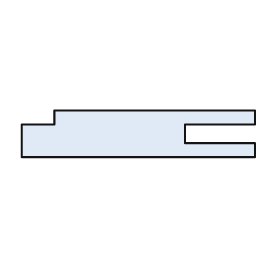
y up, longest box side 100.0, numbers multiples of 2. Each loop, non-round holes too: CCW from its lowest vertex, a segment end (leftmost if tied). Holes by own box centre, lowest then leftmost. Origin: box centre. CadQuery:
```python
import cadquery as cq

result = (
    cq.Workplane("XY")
    .moveTo(-50.0, -10.0)
    .lineTo(50.0, -10.0)
    .lineTo(50.0, -4.0)
    .lineTo(20.0, -4.0)
    .lineTo(20.0, 4.0)
    .lineTo(50.0, 4.0)
    .lineTo(50.0, 10.0)
    .lineTo(-36.0, 10.0)
    .lineTo(-36.0, 4.0)
    .lineTo(-50.0, 4.0)
    .close()
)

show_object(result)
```